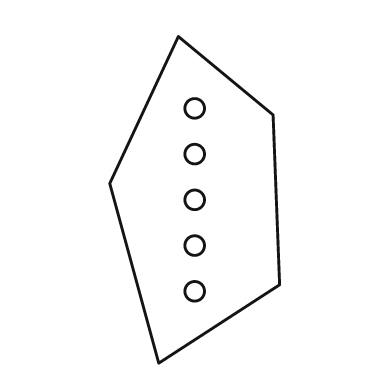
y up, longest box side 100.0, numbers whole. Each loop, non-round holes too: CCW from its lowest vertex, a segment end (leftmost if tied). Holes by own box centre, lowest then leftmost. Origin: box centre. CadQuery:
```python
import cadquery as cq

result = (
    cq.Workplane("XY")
    .moveTo(-11.0, -50.0)
    .lineTo(26.0, -26.0)
    .lineTo(24.0, 26.0)
    .lineTo(-5.0, 50.0)
    .lineTo(-26.0, 5.0)
    .close()
    .moveTo(0.0, -28.0)
    .circle(3.0)
    .moveTo(0.0, -14.0)
    .circle(3.0)
    .moveTo(0.0, 0.0)
    .circle(3.0)
    .moveTo(0.0, 14.0)
    .circle(3.0)
    .moveTo(0.0, 28.0)
    .circle(3.0)
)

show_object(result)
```